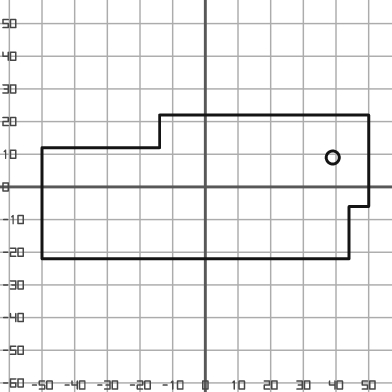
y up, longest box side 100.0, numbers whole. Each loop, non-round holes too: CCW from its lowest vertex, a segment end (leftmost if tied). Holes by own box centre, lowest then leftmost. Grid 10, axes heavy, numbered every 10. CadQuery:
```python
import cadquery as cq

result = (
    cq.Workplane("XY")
    .moveTo(-50.0, -22.0)
    .lineTo(44.0, -22.0)
    .lineTo(44.0, -6.0)
    .lineTo(50.0, -6.0)
    .lineTo(50.0, 22.0)
    .lineTo(-14.0, 22.0)
    .lineTo(-14.0, 12.0)
    .lineTo(-50.0, 12.0)
    .close()
    .moveTo(39.0, 9.0)
    .circle(2.0)
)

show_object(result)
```